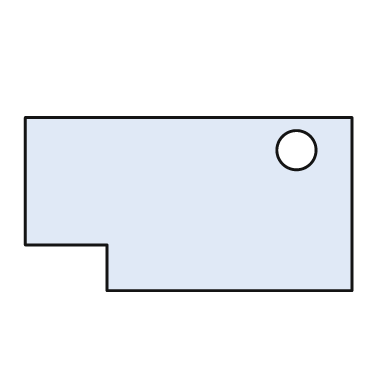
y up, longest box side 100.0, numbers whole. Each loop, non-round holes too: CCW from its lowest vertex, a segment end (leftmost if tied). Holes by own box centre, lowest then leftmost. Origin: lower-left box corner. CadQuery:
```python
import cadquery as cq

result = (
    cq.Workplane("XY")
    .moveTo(25.0, 0.0)
    .lineTo(100.0, 0.0)
    .lineTo(100.0, 53.0)
    .lineTo(0.0, 53.0)
    .lineTo(0.0, 14.0)
    .lineTo(25.0, 14.0)
    .close()
    .moveTo(83.0, 43.0)
    .circle(6.0)
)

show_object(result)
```